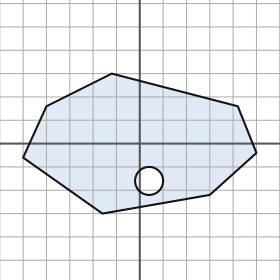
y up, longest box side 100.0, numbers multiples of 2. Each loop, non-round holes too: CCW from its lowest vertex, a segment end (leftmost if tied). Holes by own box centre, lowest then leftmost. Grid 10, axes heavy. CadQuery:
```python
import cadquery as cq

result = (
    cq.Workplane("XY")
    .moveTo(-16.0, -30.0)
    .lineTo(30.0, -22.0)
    .lineTo(50.0, -4.0)
    .lineTo(42.0, 16.0)
    .lineTo(-12.0, 30.0)
    .lineTo(-40.0, 16.0)
    .lineTo(-50.0, -6.0)
    .close()
    .moveTo(4.0, -16.0)
    .circle(6.0)
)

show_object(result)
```